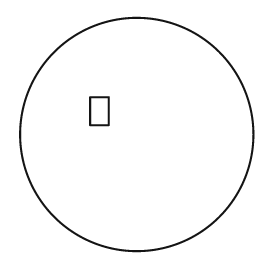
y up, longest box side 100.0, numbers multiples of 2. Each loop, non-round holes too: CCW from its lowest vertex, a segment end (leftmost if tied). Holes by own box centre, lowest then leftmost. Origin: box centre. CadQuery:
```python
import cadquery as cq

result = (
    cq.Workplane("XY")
    .moveTo(0.0, 0.0)
    .circle(50.0)
    .moveTo(-20.0, 4.0)
    .lineTo(-12.0, 4.0)
    .lineTo(-12.0, 16.0)
    .lineTo(-20.0, 16.0)
    .close()
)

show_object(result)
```